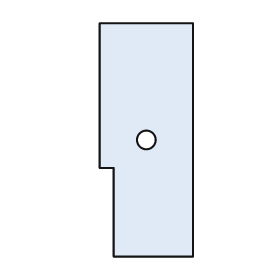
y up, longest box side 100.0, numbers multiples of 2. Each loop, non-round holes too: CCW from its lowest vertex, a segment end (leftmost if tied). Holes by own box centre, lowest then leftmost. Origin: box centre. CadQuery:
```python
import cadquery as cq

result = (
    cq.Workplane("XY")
    .moveTo(-14.0, -50.0)
    .lineTo(20.0, -50.0)
    .lineTo(20.0, 50.0)
    .lineTo(-20.0, 50.0)
    .lineTo(-20.0, -12.0)
    .lineTo(-14.0, -12.0)
    .close()
    .moveTo(0.0, 0.0)
    .circle(4.0)
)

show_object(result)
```